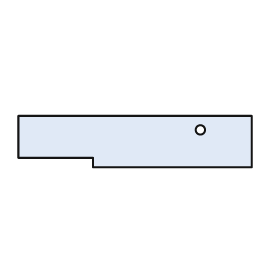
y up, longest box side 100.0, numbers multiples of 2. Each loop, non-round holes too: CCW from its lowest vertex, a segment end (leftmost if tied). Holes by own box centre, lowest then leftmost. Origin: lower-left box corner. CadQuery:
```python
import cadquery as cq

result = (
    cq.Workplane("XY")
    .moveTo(32.0, 0.0)
    .lineTo(100.0, 0.0)
    .lineTo(100.0, 22.0)
    .lineTo(0.0, 22.0)
    .lineTo(0.0, 4.0)
    .lineTo(32.0, 4.0)
    .close()
    .moveTo(78.0, 16.0)
    .circle(2.0)
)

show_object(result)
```